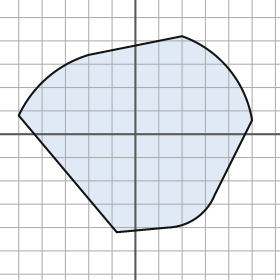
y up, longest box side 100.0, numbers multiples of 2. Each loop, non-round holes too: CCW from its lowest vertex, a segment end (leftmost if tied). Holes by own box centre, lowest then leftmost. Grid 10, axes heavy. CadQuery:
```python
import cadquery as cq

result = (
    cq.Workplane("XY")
    .moveTo(-8.0, -42.0)
    .lineTo(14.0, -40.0)
    .threePointArc((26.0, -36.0), (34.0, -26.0))
    .lineTo(50.0, 6.0)
    .threePointArc((40.0, 28.0), (20.0, 42.0))
    .lineTo(-20.0, 34.0)
    .threePointArc((-38.0, 24.0), (-50.0, 8.0))
    .close()
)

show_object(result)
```